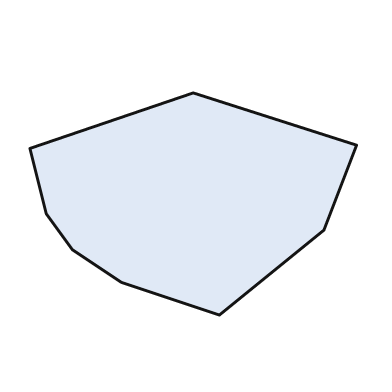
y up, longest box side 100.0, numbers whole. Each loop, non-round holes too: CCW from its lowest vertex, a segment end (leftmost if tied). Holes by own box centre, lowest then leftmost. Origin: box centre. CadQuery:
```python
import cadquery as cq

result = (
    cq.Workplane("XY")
    .moveTo(8.0, -34.0)
    .lineTo(40.0, -8.0)
    .lineTo(50.0, 18.0)
    .lineTo(0.0, 34.0)
    .lineTo(-50.0, 17.0)
    .lineTo(-45.0, -3.0)
    .lineTo(-37.0, -14.0)
    .lineTo(-22.0, -24.0)
    .close()
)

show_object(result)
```